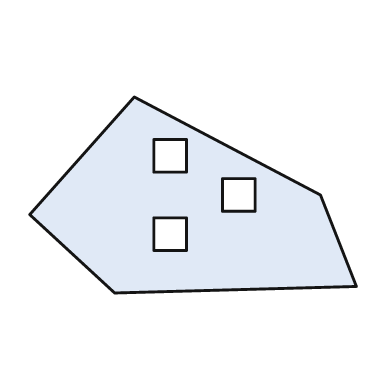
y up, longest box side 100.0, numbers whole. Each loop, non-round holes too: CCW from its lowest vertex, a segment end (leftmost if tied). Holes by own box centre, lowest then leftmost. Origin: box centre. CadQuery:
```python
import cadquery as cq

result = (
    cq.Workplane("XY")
    .moveTo(-24.0, -30.0)
    .lineTo(50.0, -28.0)
    .lineTo(39.0, 0.0)
    .lineTo(-18.0, 30.0)
    .lineTo(-50.0, -6.0)
    .close()
    .moveTo(-12.0, -17.0)
    .lineTo(-2.0, -17.0)
    .lineTo(-2.0, -7.0)
    .lineTo(-12.0, -7.0)
    .close()
    .moveTo(9.0, -5.0)
    .lineTo(19.0, -5.0)
    .lineTo(19.0, 5.0)
    .lineTo(9.0, 5.0)
    .close()
    .moveTo(-12.0, 7.0)
    .lineTo(-2.0, 7.0)
    .lineTo(-2.0, 17.0)
    .lineTo(-12.0, 17.0)
    .close()
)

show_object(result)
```